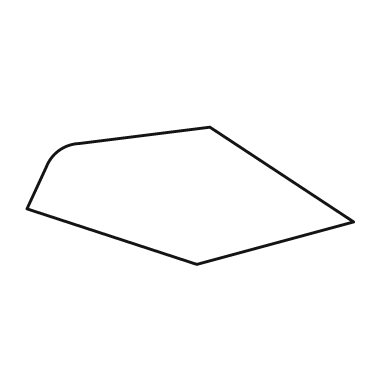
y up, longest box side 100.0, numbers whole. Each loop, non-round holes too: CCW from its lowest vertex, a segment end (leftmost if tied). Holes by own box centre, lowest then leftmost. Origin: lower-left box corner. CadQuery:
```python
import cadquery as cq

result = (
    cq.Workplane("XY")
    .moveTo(52.0, 0.0)
    .lineTo(100.0, 13.0)
    .lineTo(56.0, 42.0)
    .lineTo(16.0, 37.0)
    .threePointArc((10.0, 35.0), (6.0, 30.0))
    .lineTo(0.0, 17.0)
    .close()
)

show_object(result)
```